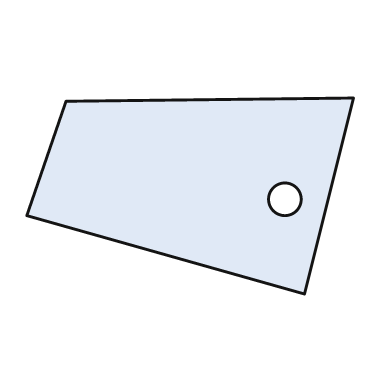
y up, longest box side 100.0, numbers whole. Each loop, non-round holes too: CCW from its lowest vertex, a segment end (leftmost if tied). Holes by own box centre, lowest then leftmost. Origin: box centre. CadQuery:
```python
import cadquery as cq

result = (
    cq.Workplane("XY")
    .moveTo(35.0, -30.0)
    .lineTo(50.0, 30.0)
    .lineTo(-38.0, 29.0)
    .lineTo(-50.0, -6.0)
    .close()
    .moveTo(29.0, -1.0)
    .circle(5.0)
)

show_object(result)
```